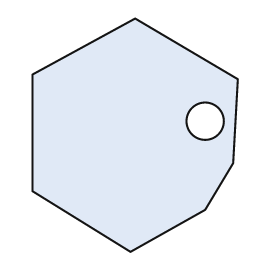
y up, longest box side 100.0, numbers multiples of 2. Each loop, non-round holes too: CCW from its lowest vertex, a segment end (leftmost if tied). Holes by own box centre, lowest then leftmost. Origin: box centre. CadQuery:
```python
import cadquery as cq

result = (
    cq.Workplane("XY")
    .moveTo(-2.0, -50.0)
    .lineTo(30.0, -32.0)
    .lineTo(42.0, -12.0)
    .lineTo(44.0, 24.0)
    .lineTo(0.0, 50.0)
    .lineTo(-44.0, 26.0)
    .lineTo(-44.0, -24.0)
    .close()
    .moveTo(30.0, 6.0)
    .circle(8.0)
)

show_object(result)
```